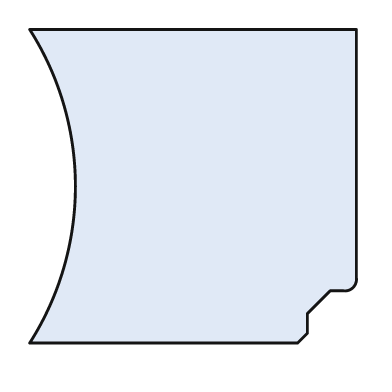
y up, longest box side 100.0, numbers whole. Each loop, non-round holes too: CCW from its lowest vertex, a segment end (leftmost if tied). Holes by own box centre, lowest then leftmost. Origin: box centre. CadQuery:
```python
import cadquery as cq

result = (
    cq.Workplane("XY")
    .moveTo(-50.0, -48.0)
    .lineTo(32.0, -48.0)
    .lineTo(35.0, -45.0)
    .lineTo(35.0, -39.0)
    .lineTo(42.0, -32.0)
    .lineTo(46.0, -32.0)
    .threePointArc((49.0, -31.0), (50.0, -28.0))
    .lineTo(50.0, 48.0)
    .lineTo(-50.0, 48.0)
    .threePointArc((-36.0, 0.0), (-50.0, -48.0))
    .close()
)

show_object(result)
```